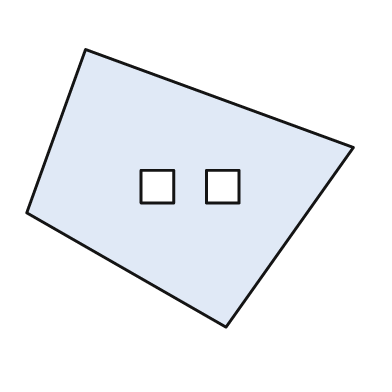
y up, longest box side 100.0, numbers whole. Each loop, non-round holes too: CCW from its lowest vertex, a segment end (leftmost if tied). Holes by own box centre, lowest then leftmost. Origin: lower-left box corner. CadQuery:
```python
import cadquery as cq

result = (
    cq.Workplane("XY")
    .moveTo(61.0, 0.0)
    .lineTo(100.0, 55.0)
    .lineTo(18.0, 85.0)
    .lineTo(0.0, 35.0)
    .close()
    .moveTo(35.0, 38.0)
    .lineTo(45.0, 38.0)
    .lineTo(45.0, 48.0)
    .lineTo(35.0, 48.0)
    .close()
    .moveTo(55.0, 38.0)
    .lineTo(65.0, 38.0)
    .lineTo(65.0, 48.0)
    .lineTo(55.0, 48.0)
    .close()
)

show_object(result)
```